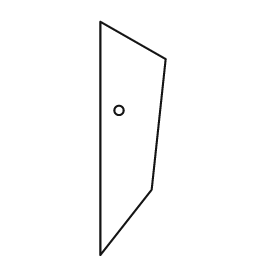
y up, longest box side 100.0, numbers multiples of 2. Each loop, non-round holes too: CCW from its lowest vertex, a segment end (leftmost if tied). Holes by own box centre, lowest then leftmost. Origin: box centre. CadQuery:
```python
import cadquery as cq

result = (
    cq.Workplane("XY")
    .moveTo(-14.0, -50.0)
    .lineTo(8.0, -22.0)
    .lineTo(14.0, 34.0)
    .lineTo(-14.0, 50.0)
    .close()
    .moveTo(-6.0, 12.0)
    .circle(2.0)
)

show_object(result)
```